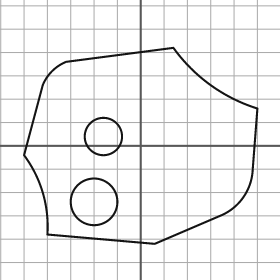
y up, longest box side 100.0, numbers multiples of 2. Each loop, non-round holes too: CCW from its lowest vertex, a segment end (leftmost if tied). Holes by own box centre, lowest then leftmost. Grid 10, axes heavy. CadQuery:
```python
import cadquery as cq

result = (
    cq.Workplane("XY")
    .moveTo(6.0, -42.0)
    .lineTo(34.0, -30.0)
    .threePointArc((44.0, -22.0), (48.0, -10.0))
    .lineTo(50.0, 16.0)
    .threePointArc((30.0, 26.0), (14.0, 42.0))
    .lineTo(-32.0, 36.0)
    .threePointArc((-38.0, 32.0), (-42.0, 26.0))
    .lineTo(-50.0, -4.0)
    .threePointArc((-42.0, -20.0), (-40.0, -38.0))
    .close()
    .moveTo(-20.0, -24.0)
    .circle(10.0)
    .moveTo(-16.0, 4.0)
    .circle(8.0)
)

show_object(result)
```